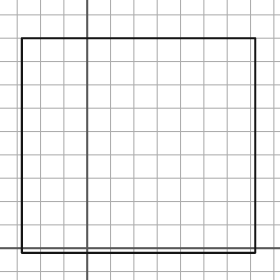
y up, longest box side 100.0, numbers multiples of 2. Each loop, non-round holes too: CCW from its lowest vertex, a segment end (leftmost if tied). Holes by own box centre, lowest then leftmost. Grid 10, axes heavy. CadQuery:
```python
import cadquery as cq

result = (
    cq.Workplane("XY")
    .moveTo(-28.0, -2.0)
    .lineTo(72.0, -2.0)
    .lineTo(72.0, 90.0)
    .lineTo(-28.0, 90.0)
    .close()
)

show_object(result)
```